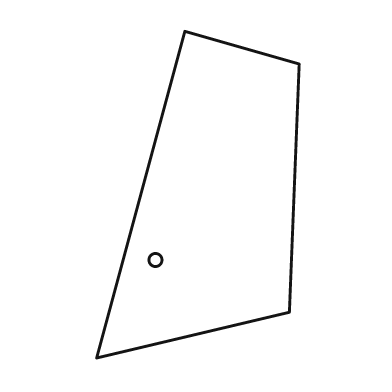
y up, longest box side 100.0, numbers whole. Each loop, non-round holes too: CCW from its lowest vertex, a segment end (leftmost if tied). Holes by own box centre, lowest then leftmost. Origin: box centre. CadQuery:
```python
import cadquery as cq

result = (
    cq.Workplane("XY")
    .moveTo(-31.0, -50.0)
    .lineTo(28.0, -36.0)
    .lineTo(31.0, 40.0)
    .lineTo(-4.0, 50.0)
    .close()
    .moveTo(-13.0, -20.0)
    .circle(2.0)
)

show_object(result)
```